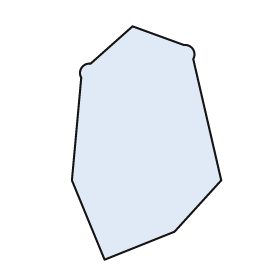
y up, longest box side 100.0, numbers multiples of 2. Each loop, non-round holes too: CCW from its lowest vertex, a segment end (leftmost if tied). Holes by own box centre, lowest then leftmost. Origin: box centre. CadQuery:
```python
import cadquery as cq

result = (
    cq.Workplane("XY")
    .moveTo(-18.0, -50.0)
    .lineTo(12.0, -38.0)
    .lineTo(32.0, -16.0)
    .lineTo(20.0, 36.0)
    .threePointArc((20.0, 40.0), (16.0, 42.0))
    .lineTo(-6.0, 50.0)
    .lineTo(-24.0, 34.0)
    .threePointArc((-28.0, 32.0), (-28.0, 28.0))
    .lineTo(-32.0, -16.0)
    .close()
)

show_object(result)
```